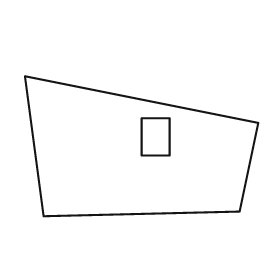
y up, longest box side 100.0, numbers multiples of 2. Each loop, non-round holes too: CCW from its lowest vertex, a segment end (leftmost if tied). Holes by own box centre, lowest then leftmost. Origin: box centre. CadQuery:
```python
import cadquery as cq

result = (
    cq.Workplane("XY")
    .moveTo(-42.0, -30.0)
    .lineTo(42.0, -28.0)
    .lineTo(50.0, 10.0)
    .lineTo(-50.0, 30.0)
    .close()
    .moveTo(0.0, -4.0)
    .lineTo(12.0, -4.0)
    .lineTo(12.0, 12.0)
    .lineTo(0.0, 12.0)
    .close()
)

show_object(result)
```